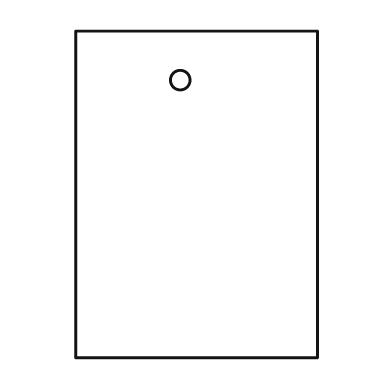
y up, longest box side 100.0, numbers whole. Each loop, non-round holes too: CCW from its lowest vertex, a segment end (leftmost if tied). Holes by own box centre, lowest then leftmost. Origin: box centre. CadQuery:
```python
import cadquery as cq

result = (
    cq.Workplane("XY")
    .moveTo(-37.0, -50.0)
    .lineTo(37.0, -50.0)
    .lineTo(37.0, 50.0)
    .lineTo(-37.0, 50.0)
    .close()
    .moveTo(-5.0, 35.0)
    .circle(3.0)
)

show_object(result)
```